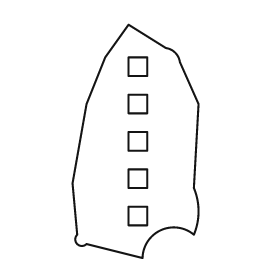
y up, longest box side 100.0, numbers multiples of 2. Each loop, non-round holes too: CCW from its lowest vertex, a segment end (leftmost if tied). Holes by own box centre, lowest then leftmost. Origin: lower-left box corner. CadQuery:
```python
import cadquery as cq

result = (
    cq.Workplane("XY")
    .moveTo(30.0, 0.0)
    .threePointArc((38.0, 12.0), (52.0, 10.0))
    .threePointArc((54.0, 20.0), (52.0, 30.0))
    .lineTo(54.0, 66.0)
    .lineTo(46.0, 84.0)
    .threePointArc((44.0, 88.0), (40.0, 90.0))
    .lineTo(24.0, 100.0)
    .lineTo(14.0, 86.0)
    .lineTo(6.0, 66.0)
    .lineTo(0.0, 32.0)
    .lineTo(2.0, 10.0)
    .threePointArc((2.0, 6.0), (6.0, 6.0))
    .close()
    .moveTo(24.0, 14.0)
    .lineTo(32.0, 14.0)
    .lineTo(32.0, 22.0)
    .lineTo(24.0, 22.0)
    .close()
    .moveTo(24.0, 30.0)
    .lineTo(32.0, 30.0)
    .lineTo(32.0, 38.0)
    .lineTo(24.0, 38.0)
    .close()
    .moveTo(24.0, 46.0)
    .lineTo(32.0, 46.0)
    .lineTo(32.0, 54.0)
    .lineTo(24.0, 54.0)
    .close()
    .moveTo(24.0, 62.0)
    .lineTo(32.0, 62.0)
    .lineTo(32.0, 70.0)
    .lineTo(24.0, 70.0)
    .close()
    .moveTo(24.0, 78.0)
    .lineTo(32.0, 78.0)
    .lineTo(32.0, 86.0)
    .lineTo(24.0, 86.0)
    .close()
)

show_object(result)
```